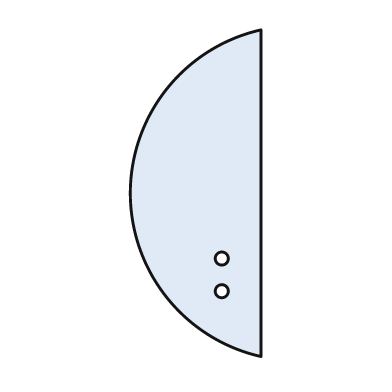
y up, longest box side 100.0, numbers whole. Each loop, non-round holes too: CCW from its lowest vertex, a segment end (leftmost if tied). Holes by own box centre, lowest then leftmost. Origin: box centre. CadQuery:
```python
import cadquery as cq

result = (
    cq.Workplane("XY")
    .moveTo(20.0, -50.0)
    .lineTo(20.0, 50.0)
    .threePointArc((-20.0, 0.0), (20.0, -50.0))
    .close()
    .moveTo(8.0, -30.0)
    .circle(2.0)
    .moveTo(8.0, -20.0)
    .circle(2.0)
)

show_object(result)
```